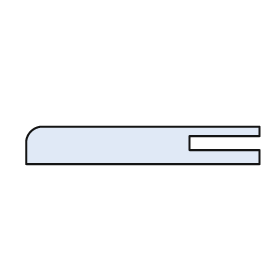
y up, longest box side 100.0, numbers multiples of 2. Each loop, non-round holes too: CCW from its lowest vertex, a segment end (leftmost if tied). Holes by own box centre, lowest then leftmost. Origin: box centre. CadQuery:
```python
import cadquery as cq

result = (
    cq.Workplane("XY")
    .moveTo(-50.0, -8.0)
    .lineTo(50.0, -8.0)
    .lineTo(50.0, -2.0)
    .lineTo(20.0, -2.0)
    .lineTo(20.0, 4.0)
    .lineTo(50.0, 4.0)
    .lineTo(50.0, 8.0)
    .lineTo(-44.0, 8.0)
    .threePointArc((-48.0, 6.0), (-50.0, 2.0))
    .close()
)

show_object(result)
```